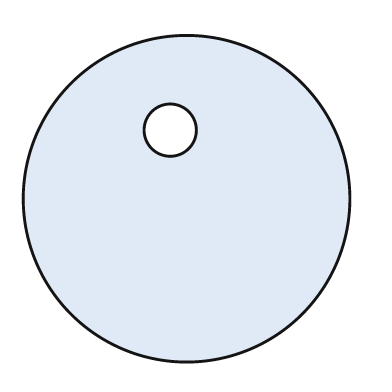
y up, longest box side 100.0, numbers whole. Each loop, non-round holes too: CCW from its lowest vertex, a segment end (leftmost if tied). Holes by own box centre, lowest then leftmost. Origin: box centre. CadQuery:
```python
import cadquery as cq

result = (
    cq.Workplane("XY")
    .moveTo(0.0, 0.0)
    .circle(50.0)
    .moveTo(-5.0, 21.0)
    .circle(8.0)
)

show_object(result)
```